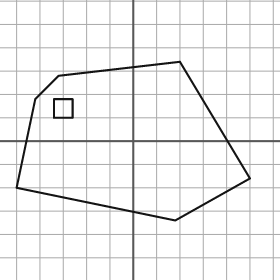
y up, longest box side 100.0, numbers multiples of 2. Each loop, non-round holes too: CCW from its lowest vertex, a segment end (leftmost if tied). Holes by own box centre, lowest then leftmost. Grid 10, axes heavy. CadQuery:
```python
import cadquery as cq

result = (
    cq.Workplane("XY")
    .moveTo(18.0, -34.0)
    .lineTo(50.0, -16.0)
    .lineTo(20.0, 34.0)
    .lineTo(-32.0, 28.0)
    .lineTo(-42.0, 18.0)
    .lineTo(-50.0, -20.0)
    .close()
    .moveTo(-34.0, 10.0)
    .lineTo(-26.0, 10.0)
    .lineTo(-26.0, 18.0)
    .lineTo(-34.0, 18.0)
    .close()
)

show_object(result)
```